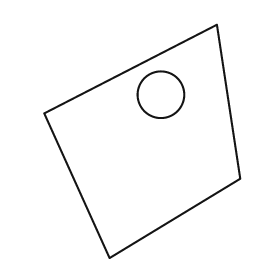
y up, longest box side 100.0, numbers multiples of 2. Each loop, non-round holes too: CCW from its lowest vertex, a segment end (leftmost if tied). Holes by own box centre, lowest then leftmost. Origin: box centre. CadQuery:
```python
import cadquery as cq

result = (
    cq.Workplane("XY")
    .moveTo(-14.0, -50.0)
    .lineTo(42.0, -16.0)
    .lineTo(32.0, 50.0)
    .lineTo(-42.0, 12.0)
    .close()
    .moveTo(8.0, 20.0)
    .circle(10.0)
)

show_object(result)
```